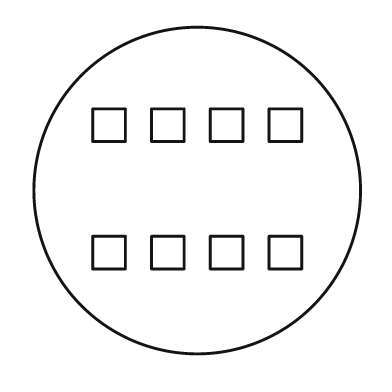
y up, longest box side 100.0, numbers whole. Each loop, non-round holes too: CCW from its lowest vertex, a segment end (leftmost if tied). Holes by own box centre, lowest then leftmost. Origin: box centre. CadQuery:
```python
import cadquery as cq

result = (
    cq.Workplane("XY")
    .moveTo(0.0, 0.0)
    .circle(50.0)
    .moveTo(-32.0, -24.0)
    .lineTo(-22.0, -24.0)
    .lineTo(-22.0, -14.0)
    .lineTo(-32.0, -14.0)
    .close()
    .moveTo(-14.0, -24.0)
    .lineTo(-4.0, -24.0)
    .lineTo(-4.0, -14.0)
    .lineTo(-14.0, -14.0)
    .close()
    .moveTo(4.0, -24.0)
    .lineTo(14.0, -24.0)
    .lineTo(14.0, -14.0)
    .lineTo(4.0, -14.0)
    .close()
    .moveTo(22.0, -24.0)
    .lineTo(32.0, -24.0)
    .lineTo(32.0, -14.0)
    .lineTo(22.0, -14.0)
    .close()
    .moveTo(-32.0, 15.0)
    .lineTo(-22.0, 15.0)
    .lineTo(-22.0, 25.0)
    .lineTo(-32.0, 25.0)
    .close()
    .moveTo(-14.0, 15.0)
    .lineTo(-4.0, 15.0)
    .lineTo(-4.0, 25.0)
    .lineTo(-14.0, 25.0)
    .close()
    .moveTo(4.0, 15.0)
    .lineTo(14.0, 15.0)
    .lineTo(14.0, 25.0)
    .lineTo(4.0, 25.0)
    .close()
    .moveTo(22.0, 15.0)
    .lineTo(32.0, 15.0)
    .lineTo(32.0, 25.0)
    .lineTo(22.0, 25.0)
    .close()
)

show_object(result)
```